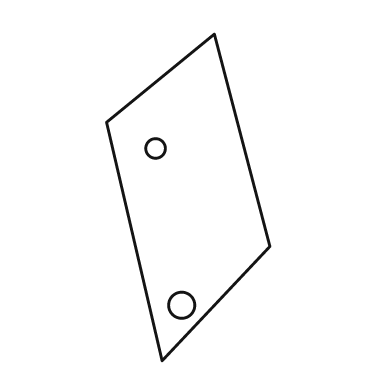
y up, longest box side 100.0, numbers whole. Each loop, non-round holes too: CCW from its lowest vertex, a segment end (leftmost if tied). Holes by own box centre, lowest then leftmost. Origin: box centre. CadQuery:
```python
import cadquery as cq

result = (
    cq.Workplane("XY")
    .moveTo(-8.0, -50.0)
    .lineTo(25.0, -15.0)
    .lineTo(8.0, 50.0)
    .lineTo(-25.0, 23.0)
    .close()
    .moveTo(-2.0, -33.0)
    .circle(4.0)
    .moveTo(-10.0, 15.0)
    .circle(3.0)
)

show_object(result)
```